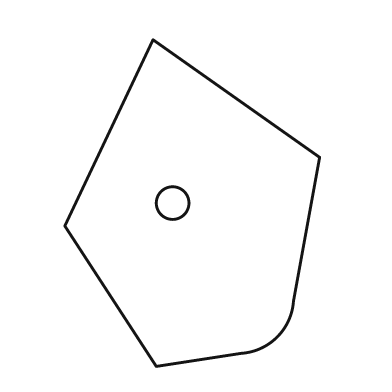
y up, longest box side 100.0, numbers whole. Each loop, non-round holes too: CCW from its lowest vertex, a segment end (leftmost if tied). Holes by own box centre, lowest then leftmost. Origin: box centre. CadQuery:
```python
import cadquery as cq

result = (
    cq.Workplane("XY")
    .moveTo(-11.0, -50.0)
    .lineTo(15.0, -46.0)
    .threePointArc((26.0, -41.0), (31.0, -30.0))
    .lineTo(39.0, 14.0)
    .lineTo(-12.0, 50.0)
    .lineTo(-39.0, -7.0)
    .close()
    .moveTo(-6.0, 0.0)
    .circle(5.0)
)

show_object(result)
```